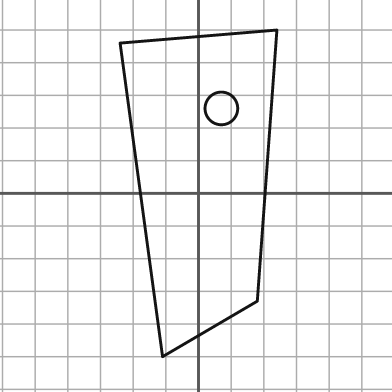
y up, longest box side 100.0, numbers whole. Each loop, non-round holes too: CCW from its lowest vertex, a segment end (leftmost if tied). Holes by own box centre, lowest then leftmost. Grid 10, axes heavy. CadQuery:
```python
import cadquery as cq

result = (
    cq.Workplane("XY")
    .moveTo(-11.0, -50.0)
    .lineTo(18.0, -33.0)
    .lineTo(24.0, 50.0)
    .lineTo(-24.0, 46.0)
    .close()
    .moveTo(7.0, 26.0)
    .circle(5.0)
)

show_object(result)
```